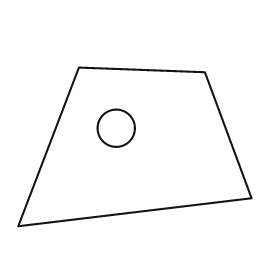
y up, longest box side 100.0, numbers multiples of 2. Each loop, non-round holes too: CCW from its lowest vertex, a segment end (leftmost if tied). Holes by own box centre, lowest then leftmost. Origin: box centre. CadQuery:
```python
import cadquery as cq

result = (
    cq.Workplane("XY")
    .moveTo(-50.0, -34.0)
    .lineTo(50.0, -22.0)
    .lineTo(30.0, 32.0)
    .lineTo(-24.0, 34.0)
    .close()
    .moveTo(-8.0, 8.0)
    .circle(8.0)
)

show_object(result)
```